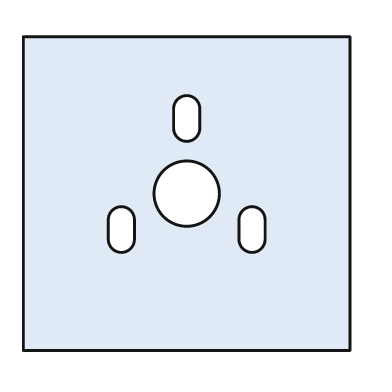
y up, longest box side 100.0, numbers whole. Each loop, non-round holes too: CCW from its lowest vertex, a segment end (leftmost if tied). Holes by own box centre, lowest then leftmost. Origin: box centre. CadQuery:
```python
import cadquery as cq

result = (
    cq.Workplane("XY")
    .moveTo(-50.0, -48.0)
    .lineTo(50.0, -48.0)
    .lineTo(50.0, 48.0)
    .lineTo(-50.0, 48.0)
    .close()
    .moveTo(-24.0, -14.0)
    .threePointArc((-20.0, -18.0), (-16.0, -14.0))
    .lineTo(-16.0, -8.0)
    .threePointArc((-20.0, -4.0), (-24.0, -8.0))
    .close()
    .moveTo(16.0, -14.0)
    .threePointArc((20.0, -18.0), (24.0, -14.0))
    .lineTo(24.0, -8.0)
    .threePointArc((20.0, -4.0), (16.0, -8.0))
    .close()
    .moveTo(0.0, 0.0)
    .circle(10.0)
    .moveTo(-4.0, 20.0)
    .threePointArc((0.0, 16.0), (4.0, 20.0))
    .lineTo(4.0, 26.0)
    .threePointArc((0.0, 30.0), (-4.0, 26.0))
    .close()
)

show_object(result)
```